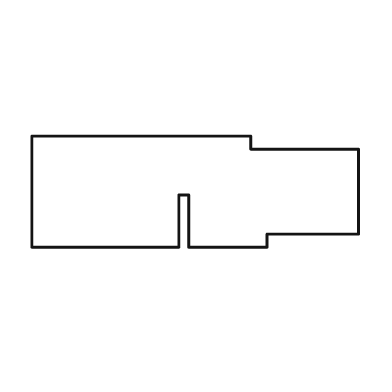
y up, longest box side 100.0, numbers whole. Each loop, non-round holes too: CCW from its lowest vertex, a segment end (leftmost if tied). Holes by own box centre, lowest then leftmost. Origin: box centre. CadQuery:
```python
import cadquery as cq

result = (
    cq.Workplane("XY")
    .moveTo(-50.0, -17.0)
    .lineTo(-5.0, -17.0)
    .lineTo(-5.0, -1.0)
    .lineTo(-2.0, -1.0)
    .lineTo(-2.0, -17.0)
    .lineTo(22.0, -17.0)
    .lineTo(22.0, -13.0)
    .lineTo(50.0, -13.0)
    .lineTo(50.0, 13.0)
    .lineTo(17.0, 13.0)
    .lineTo(17.0, 17.0)
    .lineTo(-50.0, 17.0)
    .close()
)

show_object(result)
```